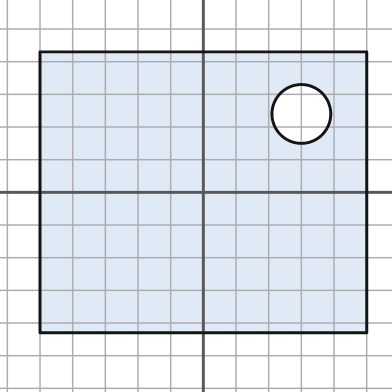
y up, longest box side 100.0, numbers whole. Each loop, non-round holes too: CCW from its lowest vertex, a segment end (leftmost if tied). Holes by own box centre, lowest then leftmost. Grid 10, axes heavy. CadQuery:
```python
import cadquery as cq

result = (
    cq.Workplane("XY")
    .moveTo(-50.0, -43.0)
    .lineTo(50.0, -43.0)
    .lineTo(50.0, 43.0)
    .lineTo(-50.0, 43.0)
    .close()
    .moveTo(30.0, 24.0)
    .circle(9.0)
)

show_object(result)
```